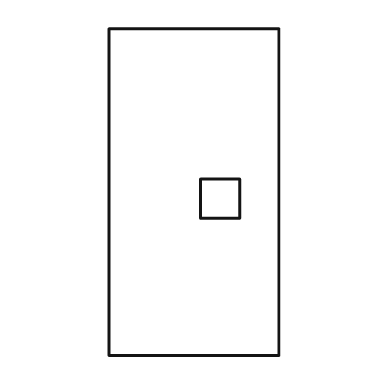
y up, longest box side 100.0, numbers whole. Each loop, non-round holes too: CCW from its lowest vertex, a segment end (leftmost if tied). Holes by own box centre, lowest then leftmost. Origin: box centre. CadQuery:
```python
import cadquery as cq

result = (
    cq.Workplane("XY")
    .moveTo(-26.0, -50.0)
    .lineTo(26.0, -50.0)
    .lineTo(26.0, 50.0)
    .lineTo(-26.0, 50.0)
    .close()
    .moveTo(2.0, -8.0)
    .lineTo(14.0, -8.0)
    .lineTo(14.0, 4.0)
    .lineTo(2.0, 4.0)
    .close()
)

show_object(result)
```